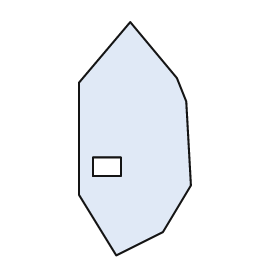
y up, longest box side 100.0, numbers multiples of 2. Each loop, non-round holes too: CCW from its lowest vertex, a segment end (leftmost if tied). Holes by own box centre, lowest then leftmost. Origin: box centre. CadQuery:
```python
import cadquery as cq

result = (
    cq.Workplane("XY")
    .moveTo(-8.0, -50.0)
    .lineTo(12.0, -40.0)
    .lineTo(24.0, -20.0)
    .lineTo(22.0, 16.0)
    .lineTo(18.0, 26.0)
    .lineTo(-2.0, 50.0)
    .lineTo(-24.0, 24.0)
    .lineTo(-24.0, -24.0)
    .close()
    .moveTo(-18.0, -16.0)
    .lineTo(-6.0, -16.0)
    .lineTo(-6.0, -8.0)
    .lineTo(-18.0, -8.0)
    .close()
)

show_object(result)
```